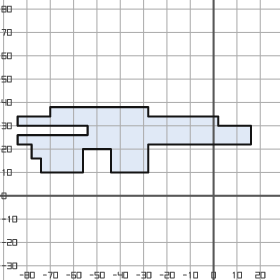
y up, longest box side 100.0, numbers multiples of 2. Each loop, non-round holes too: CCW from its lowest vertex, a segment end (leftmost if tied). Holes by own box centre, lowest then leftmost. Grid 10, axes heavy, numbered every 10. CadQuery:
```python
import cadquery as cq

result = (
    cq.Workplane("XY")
    .moveTo(-74.0, 10.0)
    .lineTo(-56.0, 10.0)
    .lineTo(-56.0, 20.0)
    .lineTo(-44.0, 20.0)
    .lineTo(-44.0, 10.0)
    .lineTo(-28.0, 10.0)
    .lineTo(-28.0, 22.0)
    .lineTo(16.0, 22.0)
    .lineTo(16.0, 30.0)
    .lineTo(2.0, 30.0)
    .lineTo(2.0, 34.0)
    .lineTo(-28.0, 34.0)
    .lineTo(-28.0, 38.0)
    .lineTo(-70.0, 38.0)
    .lineTo(-70.0, 34.0)
    .lineTo(-84.0, 34.0)
    .lineTo(-84.0, 30.0)
    .lineTo(-54.0, 30.0)
    .lineTo(-54.0, 26.0)
    .lineTo(-84.0, 26.0)
    .lineTo(-84.0, 22.0)
    .lineTo(-78.0, 22.0)
    .lineTo(-78.0, 16.0)
    .lineTo(-74.0, 16.0)
    .close()
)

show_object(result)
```